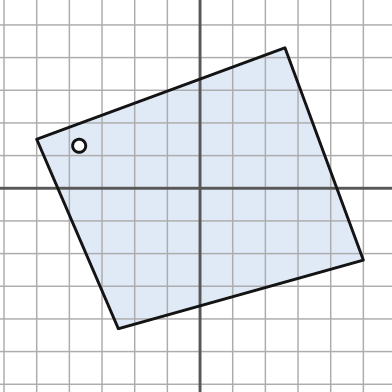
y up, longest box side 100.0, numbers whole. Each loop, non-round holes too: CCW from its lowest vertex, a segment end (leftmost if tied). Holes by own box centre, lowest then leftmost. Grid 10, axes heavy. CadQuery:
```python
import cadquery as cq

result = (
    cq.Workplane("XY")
    .moveTo(-25.0, -43.0)
    .lineTo(50.0, -22.0)
    .lineTo(26.0, 43.0)
    .lineTo(-50.0, 15.0)
    .close()
    .moveTo(-37.0, 13.0)
    .circle(2.0)
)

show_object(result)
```